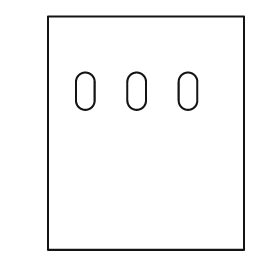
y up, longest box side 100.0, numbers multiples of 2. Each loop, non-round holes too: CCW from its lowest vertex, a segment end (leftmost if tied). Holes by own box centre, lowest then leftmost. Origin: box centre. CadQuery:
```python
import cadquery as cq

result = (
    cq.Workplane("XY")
    .moveTo(-42.0, -50.0)
    .lineTo(42.0, -50.0)
    .lineTo(42.0, 50.0)
    .lineTo(-42.0, 50.0)
    .close()
    .moveTo(-30.0, 14.0)
    .threePointArc((-26.0, 10.0), (-22.0, 14.0))
    .lineTo(-22.0, 22.0)
    .threePointArc((-26.0, 26.0), (-30.0, 22.0))
    .close()
    .moveTo(-8.0, 14.0)
    .threePointArc((-4.0, 10.0), (0.0, 14.0))
    .lineTo(0.0, 22.0)
    .threePointArc((-4.0, 26.0), (-8.0, 22.0))
    .close()
    .moveTo(14.0, 14.0)
    .threePointArc((18.0, 10.0), (22.0, 14.0))
    .lineTo(22.0, 22.0)
    .threePointArc((18.0, 26.0), (14.0, 22.0))
    .close()
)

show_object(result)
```